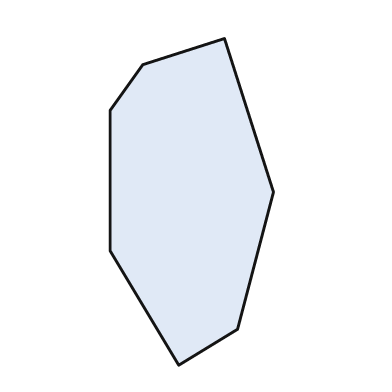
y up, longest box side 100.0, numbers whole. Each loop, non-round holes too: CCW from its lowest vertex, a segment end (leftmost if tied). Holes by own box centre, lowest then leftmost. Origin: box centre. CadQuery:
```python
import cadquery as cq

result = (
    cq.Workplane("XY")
    .moveTo(-4.0, -50.0)
    .lineTo(14.0, -39.0)
    .lineTo(25.0, 3.0)
    .lineTo(10.0, 50.0)
    .lineTo(-15.0, 42.0)
    .lineTo(-25.0, 28.0)
    .lineTo(-25.0, -15.0)
    .close()
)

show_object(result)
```